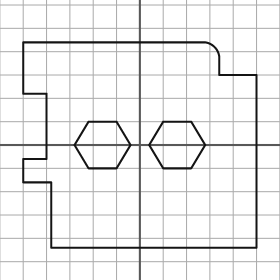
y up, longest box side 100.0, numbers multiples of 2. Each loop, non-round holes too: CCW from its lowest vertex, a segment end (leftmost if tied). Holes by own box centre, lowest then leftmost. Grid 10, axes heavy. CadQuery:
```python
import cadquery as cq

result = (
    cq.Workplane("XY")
    .moveTo(-38.0, -44.0)
    .lineTo(50.0, -44.0)
    .lineTo(50.0, 30.0)
    .lineTo(34.0, 30.0)
    .lineTo(34.0, 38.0)
    .threePointArc((32.0, 42.0), (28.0, 44.0))
    .lineTo(-50.0, 44.0)
    .lineTo(-50.0, 22.0)
    .lineTo(-40.0, 22.0)
    .lineTo(-40.0, -6.0)
    .lineTo(-50.0, -6.0)
    .lineTo(-50.0, -16.0)
    .lineTo(-38.0, -16.0)
    .close()
    .moveTo(-22.0, -10.0)
    .lineTo(-10.0, -10.0)
    .lineTo(-4.0, 0.0)
    .lineTo(-10.0, 10.0)
    .lineTo(-22.0, 10.0)
    .lineTo(-28.0, 0.0)
    .close()
    .moveTo(10.0, -10.0)
    .lineTo(22.0, -10.0)
    .lineTo(28.0, 0.0)
    .lineTo(22.0, 10.0)
    .lineTo(10.0, 10.0)
    .lineTo(4.0, 0.0)
    .close()
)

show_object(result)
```